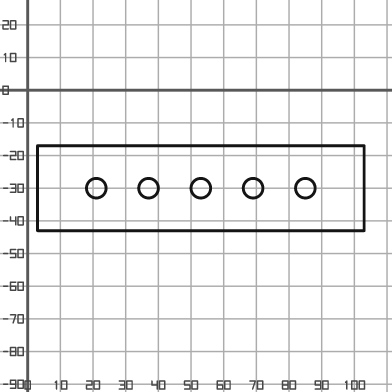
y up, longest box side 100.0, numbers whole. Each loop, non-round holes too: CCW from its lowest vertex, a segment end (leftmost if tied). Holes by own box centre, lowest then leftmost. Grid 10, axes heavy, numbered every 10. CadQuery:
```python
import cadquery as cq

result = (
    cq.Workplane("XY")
    .moveTo(3.0, -43.0)
    .lineTo(103.0, -43.0)
    .lineTo(103.0, -17.0)
    .lineTo(3.0, -17.0)
    .close()
    .moveTo(21.0, -30.0)
    .circle(3.0)
    .moveTo(37.0, -30.0)
    .circle(3.0)
    .moveTo(53.0, -30.0)
    .circle(3.0)
    .moveTo(69.0, -30.0)
    .circle(3.0)
    .moveTo(85.0, -30.0)
    .circle(3.0)
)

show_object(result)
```